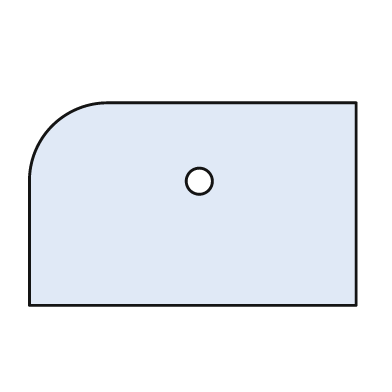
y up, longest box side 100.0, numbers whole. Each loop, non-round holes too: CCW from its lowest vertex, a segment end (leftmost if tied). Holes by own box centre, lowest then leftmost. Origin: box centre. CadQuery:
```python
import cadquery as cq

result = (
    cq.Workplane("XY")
    .moveTo(-50.0, -31.0)
    .lineTo(50.0, -31.0)
    .lineTo(50.0, 31.0)
    .lineTo(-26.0, 31.0)
    .threePointArc((-43.0, 24.0), (-50.0, 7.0))
    .close()
    .moveTo(2.0, 7.0)
    .circle(4.0)
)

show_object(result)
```